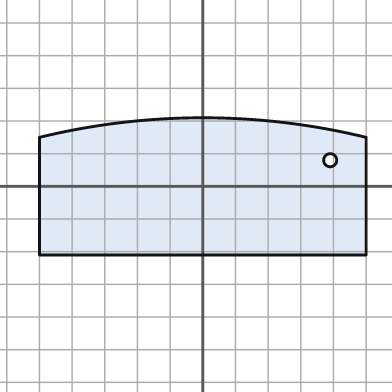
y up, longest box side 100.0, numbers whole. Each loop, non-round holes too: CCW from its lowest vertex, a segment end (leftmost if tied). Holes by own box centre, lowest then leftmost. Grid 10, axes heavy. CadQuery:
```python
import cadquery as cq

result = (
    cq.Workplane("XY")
    .moveTo(-50.0, -21.0)
    .lineTo(50.0, -21.0)
    .lineTo(50.0, 15.0)
    .threePointArc((0.0, 21.0), (-50.0, 15.0))
    .close()
    .moveTo(39.0, 8.0)
    .circle(2.0)
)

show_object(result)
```